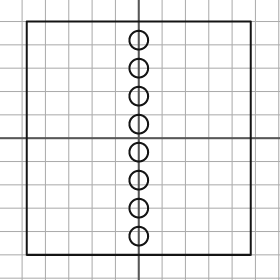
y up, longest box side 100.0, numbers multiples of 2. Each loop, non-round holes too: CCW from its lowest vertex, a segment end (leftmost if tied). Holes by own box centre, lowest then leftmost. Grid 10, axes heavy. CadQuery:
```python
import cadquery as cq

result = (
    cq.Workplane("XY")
    .moveTo(-48.0, -50.0)
    .lineTo(48.0, -50.0)
    .lineTo(48.0, 50.0)
    .lineTo(-48.0, 50.0)
    .close()
    .moveTo(0.0, -42.0)
    .circle(4.0)
    .moveTo(0.0, -30.0)
    .circle(4.0)
    .moveTo(0.0, -18.0)
    .circle(4.0)
    .moveTo(0.0, -6.0)
    .circle(4.0)
    .moveTo(0.0, 6.0)
    .circle(4.0)
    .moveTo(0.0, 18.0)
    .circle(4.0)
    .moveTo(0.0, 30.0)
    .circle(4.0)
    .moveTo(0.0, 42.0)
    .circle(4.0)
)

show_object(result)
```